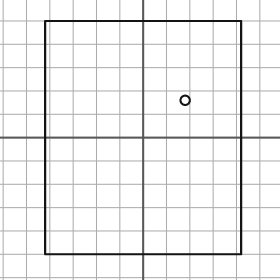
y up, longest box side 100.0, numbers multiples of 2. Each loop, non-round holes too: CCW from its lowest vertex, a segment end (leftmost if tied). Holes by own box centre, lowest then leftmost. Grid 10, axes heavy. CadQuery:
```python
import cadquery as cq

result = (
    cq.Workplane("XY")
    .moveTo(-42.0, -50.0)
    .lineTo(42.0, -50.0)
    .lineTo(42.0, 50.0)
    .lineTo(-42.0, 50.0)
    .close()
    .moveTo(18.0, 16.0)
    .circle(2.0)
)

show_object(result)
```